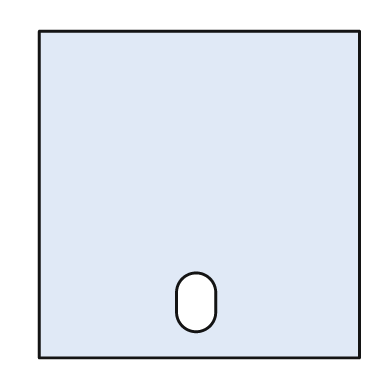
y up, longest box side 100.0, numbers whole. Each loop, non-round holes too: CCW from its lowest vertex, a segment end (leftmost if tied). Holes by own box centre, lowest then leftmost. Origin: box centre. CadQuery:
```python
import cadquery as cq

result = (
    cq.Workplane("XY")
    .moveTo(-49.0, -50.0)
    .lineTo(49.0, -50.0)
    .lineTo(49.0, 50.0)
    .lineTo(-49.0, 50.0)
    .close()
    .moveTo(-7.0, -36.0)
    .threePointArc((-1.0, -42.0), (5.0, -36.0))
    .lineTo(5.0, -30.0)
    .threePointArc((-1.0, -24.0), (-7.0, -30.0))
    .close()
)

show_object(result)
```